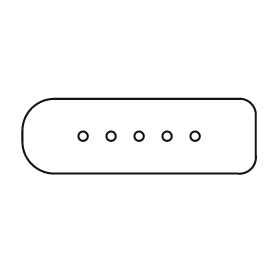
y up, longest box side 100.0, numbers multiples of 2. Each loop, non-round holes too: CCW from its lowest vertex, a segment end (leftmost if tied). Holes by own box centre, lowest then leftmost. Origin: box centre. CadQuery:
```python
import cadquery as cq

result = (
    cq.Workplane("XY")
    .moveTo(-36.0, -16.0)
    .lineTo(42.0, -16.0)
    .threePointArc((48.0, -14.0), (50.0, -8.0))
    .lineTo(50.0, 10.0)
    .threePointArc((48.0, 14.0), (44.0, 16.0))
    .lineTo(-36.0, 16.0)
    .threePointArc((-46.0, 12.0), (-50.0, 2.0))
    .lineTo(-50.0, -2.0)
    .threePointArc((-46.0, -12.0), (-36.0, -16.0))
    .close()
    .moveTo(-24.0, 0.0)
    .circle(2.0)
    .moveTo(-12.0, 0.0)
    .circle(2.0)
    .moveTo(0.0, 0.0)
    .circle(2.0)
    .moveTo(12.0, 0.0)
    .circle(2.0)
    .moveTo(24.0, 0.0)
    .circle(2.0)
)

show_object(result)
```